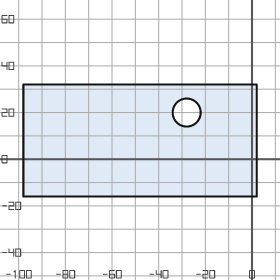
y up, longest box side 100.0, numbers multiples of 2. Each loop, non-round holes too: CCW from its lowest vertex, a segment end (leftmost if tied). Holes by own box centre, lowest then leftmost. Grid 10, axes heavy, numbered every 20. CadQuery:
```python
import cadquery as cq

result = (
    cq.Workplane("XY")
    .moveTo(-98.0, -16.0)
    .lineTo(2.0, -16.0)
    .lineTo(2.0, 32.0)
    .lineTo(-98.0, 32.0)
    .close()
    .moveTo(-28.0, 20.0)
    .circle(6.0)
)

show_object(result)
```